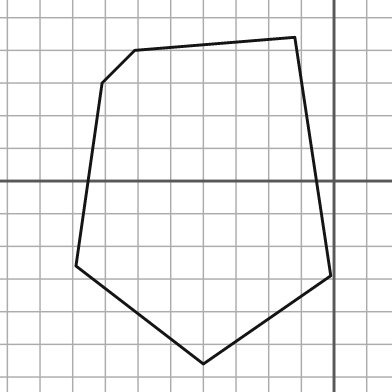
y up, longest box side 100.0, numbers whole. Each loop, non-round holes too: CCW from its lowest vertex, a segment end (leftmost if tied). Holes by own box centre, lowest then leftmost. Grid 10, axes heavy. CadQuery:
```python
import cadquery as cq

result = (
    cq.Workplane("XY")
    .moveTo(-40.0, -56.0)
    .lineTo(-1.0, -29.0)
    .lineTo(-12.0, 44.0)
    .lineTo(-61.0, 40.0)
    .lineTo(-71.0, 30.0)
    .lineTo(-79.0, -26.0)
    .close()
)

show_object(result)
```